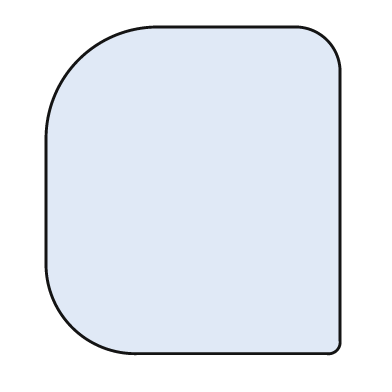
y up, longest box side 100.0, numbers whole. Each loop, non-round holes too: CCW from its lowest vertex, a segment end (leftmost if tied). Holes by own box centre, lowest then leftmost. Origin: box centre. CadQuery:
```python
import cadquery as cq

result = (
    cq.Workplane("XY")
    .moveTo(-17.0, -50.0)
    .lineTo(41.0, -50.0)
    .threePointArc((44.0, -49.0), (45.0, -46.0))
    .lineTo(45.0, 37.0)
    .threePointArc((41.0, 46.0), (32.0, 50.0))
    .lineTo(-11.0, 50.0)
    .threePointArc((-35.0, 40.0), (-45.0, 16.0))
    .lineTo(-45.0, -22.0)
    .threePointArc((-37.0, -42.0), (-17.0, -50.0))
    .close()
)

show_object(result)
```